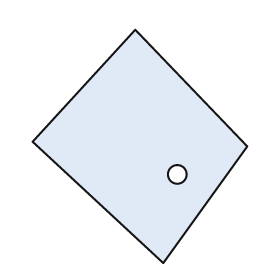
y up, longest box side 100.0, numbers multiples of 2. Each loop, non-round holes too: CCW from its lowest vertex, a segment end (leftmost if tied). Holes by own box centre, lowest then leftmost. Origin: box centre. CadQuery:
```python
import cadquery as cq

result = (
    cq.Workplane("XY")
    .moveTo(10.0, -50.0)
    .lineTo(46.0, 0.0)
    .lineTo(-2.0, 50.0)
    .lineTo(-46.0, 2.0)
    .close()
    .moveTo(16.0, -12.0)
    .circle(4.0)
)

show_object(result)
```